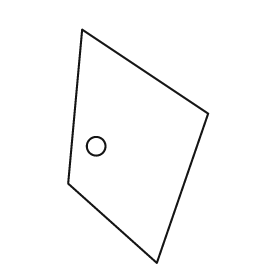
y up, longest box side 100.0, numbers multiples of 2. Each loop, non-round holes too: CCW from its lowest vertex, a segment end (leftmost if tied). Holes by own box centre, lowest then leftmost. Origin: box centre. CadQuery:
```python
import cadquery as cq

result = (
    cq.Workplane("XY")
    .moveTo(8.0, -50.0)
    .lineTo(30.0, 14.0)
    .lineTo(-24.0, 50.0)
    .lineTo(-30.0, -16.0)
    .close()
    .moveTo(-18.0, 0.0)
    .circle(4.0)
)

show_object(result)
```